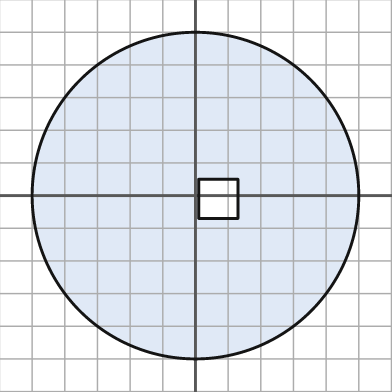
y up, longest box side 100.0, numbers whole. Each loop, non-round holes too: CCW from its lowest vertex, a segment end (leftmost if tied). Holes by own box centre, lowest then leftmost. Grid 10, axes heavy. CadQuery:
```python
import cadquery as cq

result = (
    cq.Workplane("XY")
    .moveTo(0.0, 0.0)
    .circle(50.0)
    .moveTo(1.0, -7.0)
    .lineTo(13.0, -7.0)
    .lineTo(13.0, 5.0)
    .lineTo(1.0, 5.0)
    .close()
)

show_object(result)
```